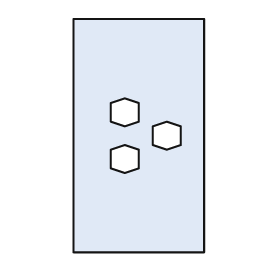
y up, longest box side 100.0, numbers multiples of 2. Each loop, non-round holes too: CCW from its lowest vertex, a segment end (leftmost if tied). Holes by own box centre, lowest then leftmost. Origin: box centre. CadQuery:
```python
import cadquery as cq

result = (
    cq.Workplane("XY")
    .moveTo(-28.0, -50.0)
    .lineTo(28.0, -50.0)
    .lineTo(28.0, 50.0)
    .lineTo(-28.0, 50.0)
    .close()
    .moveTo(-6.0, -16.0)
    .lineTo(0.0, -14.0)
    .lineTo(0.0, -6.0)
    .lineTo(-6.0, -4.0)
    .lineTo(-12.0, -6.0)
    .lineTo(-12.0, -14.0)
    .close()
    .moveTo(12.0, -6.0)
    .lineTo(18.0, -4.0)
    .lineTo(18.0, 4.0)
    .lineTo(12.0, 6.0)
    .lineTo(6.0, 4.0)
    .lineTo(6.0, -4.0)
    .close()
    .moveTo(-6.0, 4.0)
    .lineTo(0.0, 6.0)
    .lineTo(0.0, 14.0)
    .lineTo(-6.0, 16.0)
    .lineTo(-12.0, 14.0)
    .lineTo(-12.0, 6.0)
    .close()
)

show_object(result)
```